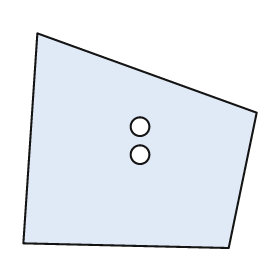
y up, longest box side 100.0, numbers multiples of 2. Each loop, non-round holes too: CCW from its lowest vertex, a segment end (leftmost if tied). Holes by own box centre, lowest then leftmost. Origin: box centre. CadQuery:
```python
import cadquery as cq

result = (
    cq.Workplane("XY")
    .moveTo(38.0, -46.0)
    .lineTo(50.0, 12.0)
    .lineTo(-44.0, 46.0)
    .lineTo(-50.0, -44.0)
    .close()
    .moveTo(0.0, -6.0)
    .circle(4.0)
    .moveTo(0.0, 6.0)
    .circle(4.0)
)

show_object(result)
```